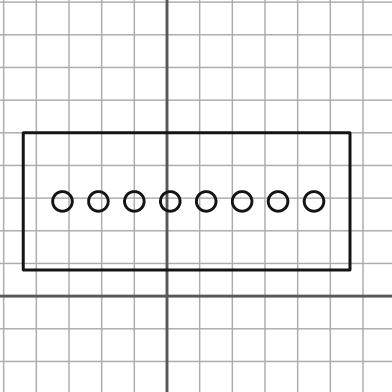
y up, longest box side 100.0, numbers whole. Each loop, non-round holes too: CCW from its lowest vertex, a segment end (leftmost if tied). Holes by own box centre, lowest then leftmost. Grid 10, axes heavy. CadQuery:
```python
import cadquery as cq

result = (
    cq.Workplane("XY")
    .moveTo(-44.0, 8.0)
    .lineTo(56.0, 8.0)
    .lineTo(56.0, 50.0)
    .lineTo(-44.0, 50.0)
    .close()
    .moveTo(-32.0, 29.0)
    .circle(3.0)
    .moveTo(-21.0, 29.0)
    .circle(3.0)
    .moveTo(-10.0, 29.0)
    .circle(3.0)
    .moveTo(1.0, 29.0)
    .circle(3.0)
    .moveTo(12.0, 29.0)
    .circle(3.0)
    .moveTo(23.0, 29.0)
    .circle(3.0)
    .moveTo(34.0, 29.0)
    .circle(3.0)
    .moveTo(45.0, 29.0)
    .circle(3.0)
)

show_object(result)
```